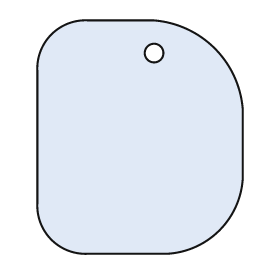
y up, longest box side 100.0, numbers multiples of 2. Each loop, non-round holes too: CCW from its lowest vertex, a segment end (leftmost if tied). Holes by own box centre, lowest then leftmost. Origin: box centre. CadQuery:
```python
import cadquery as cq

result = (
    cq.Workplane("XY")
    .moveTo(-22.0, -50.0)
    .lineTo(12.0, -50.0)
    .threePointArc((34.0, -40.0), (44.0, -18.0))
    .lineTo(44.0, 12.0)
    .threePointArc((32.0, 38.0), (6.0, 50.0))
    .lineTo(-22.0, 50.0)
    .threePointArc((-38.0, 44.0), (-44.0, 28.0))
    .lineTo(-44.0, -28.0)
    .threePointArc((-38.0, -44.0), (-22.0, -50.0))
    .close()
    .moveTo(6.0, 36.0)
    .circle(4.0)
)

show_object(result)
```